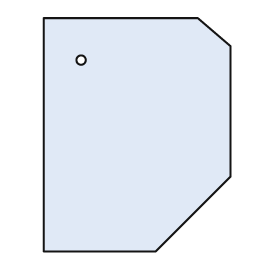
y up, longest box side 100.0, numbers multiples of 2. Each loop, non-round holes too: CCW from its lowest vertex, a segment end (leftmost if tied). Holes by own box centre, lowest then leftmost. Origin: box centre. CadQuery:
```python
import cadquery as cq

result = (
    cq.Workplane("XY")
    .moveTo(-40.0, -50.0)
    .lineTo(8.0, -50.0)
    .lineTo(40.0, -18.0)
    .lineTo(40.0, 38.0)
    .lineTo(26.0, 50.0)
    .lineTo(-40.0, 50.0)
    .close()
    .moveTo(-24.0, 32.0)
    .circle(2.0)
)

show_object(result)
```